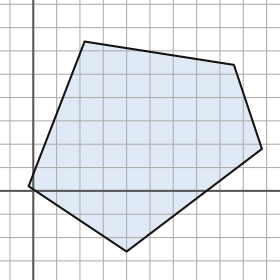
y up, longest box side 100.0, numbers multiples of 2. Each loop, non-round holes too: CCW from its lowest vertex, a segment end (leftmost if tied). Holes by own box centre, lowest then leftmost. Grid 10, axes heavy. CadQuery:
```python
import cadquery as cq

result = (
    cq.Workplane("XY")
    .moveTo(40.0, -26.0)
    .lineTo(98.0, 18.0)
    .lineTo(86.0, 54.0)
    .lineTo(22.0, 64.0)
    .lineTo(-2.0, 2.0)
    .close()
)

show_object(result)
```